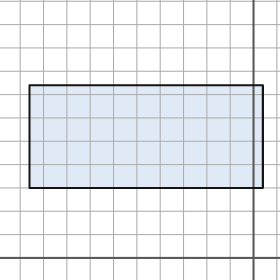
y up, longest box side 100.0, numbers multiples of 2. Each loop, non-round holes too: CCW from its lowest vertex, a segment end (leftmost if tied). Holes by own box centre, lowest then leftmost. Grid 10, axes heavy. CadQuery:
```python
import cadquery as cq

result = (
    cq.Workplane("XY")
    .moveTo(-96.0, 30.0)
    .lineTo(4.0, 30.0)
    .lineTo(4.0, 74.0)
    .lineTo(-96.0, 74.0)
    .close()
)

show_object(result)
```